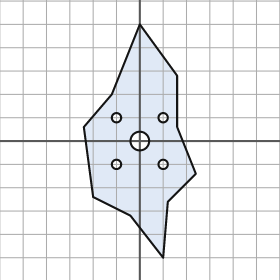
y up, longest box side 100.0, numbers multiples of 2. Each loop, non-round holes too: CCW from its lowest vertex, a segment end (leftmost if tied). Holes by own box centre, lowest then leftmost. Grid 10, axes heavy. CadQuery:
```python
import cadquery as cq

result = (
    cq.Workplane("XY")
    .moveTo(10.0, -50.0)
    .lineTo(12.0, -26.0)
    .lineTo(24.0, -14.0)
    .lineTo(16.0, 6.0)
    .lineTo(16.0, 28.0)
    .lineTo(0.0, 50.0)
    .lineTo(-12.0, 20.0)
    .lineTo(-24.0, 6.0)
    .lineTo(-20.0, -24.0)
    .lineTo(-4.0, -32.0)
    .close()
    .moveTo(-10.0, -10.0)
    .circle(2.0)
    .moveTo(10.0, -10.0)
    .circle(2.0)
    .moveTo(0.0, 0.0)
    .circle(4.0)
    .moveTo(-10.0, 10.0)
    .circle(2.0)
    .moveTo(10.0, 10.0)
    .circle(2.0)
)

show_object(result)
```